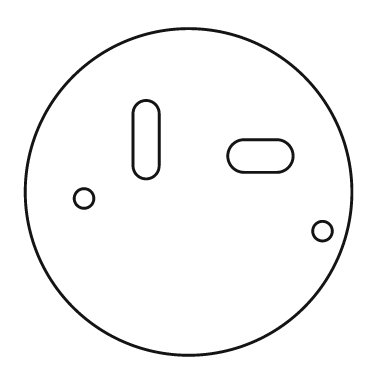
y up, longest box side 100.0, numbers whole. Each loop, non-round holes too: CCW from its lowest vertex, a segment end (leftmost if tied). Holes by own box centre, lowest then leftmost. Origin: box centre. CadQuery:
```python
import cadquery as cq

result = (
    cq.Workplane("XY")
    .moveTo(0.0, 0.0)
    .circle(50.0)
    .moveTo(41.0, -12.0)
    .circle(3.0)
    .moveTo(-32.0, -2.0)
    .circle(3.0)
    .moveTo(17.0, 6.0)
    .lineTo(27.0, 6.0)
    .threePointArc((32.0, 11.0), (27.0, 16.0))
    .lineTo(17.0, 16.0)
    .threePointArc((12.0, 11.0), (17.0, 6.0))
    .close()
    .moveTo(-17.0, 8.0)
    .threePointArc((-13.0, 4.0), (-9.0, 8.0))
    .lineTo(-9.0, 24.0)
    .threePointArc((-13.0, 28.0), (-17.0, 24.0))
    .close()
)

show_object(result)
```